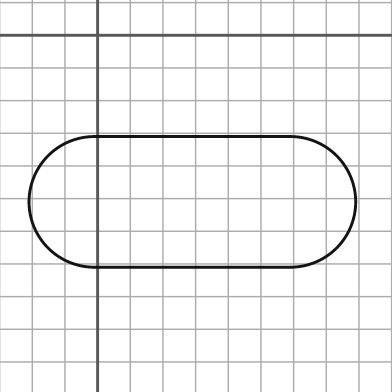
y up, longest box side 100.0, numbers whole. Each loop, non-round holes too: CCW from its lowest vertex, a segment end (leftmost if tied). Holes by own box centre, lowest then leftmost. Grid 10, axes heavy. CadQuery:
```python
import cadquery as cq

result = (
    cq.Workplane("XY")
    .moveTo(-1.0, -71.0)
    .lineTo(59.0, -71.0)
    .threePointArc((79.0, -51.0), (59.0, -31.0))
    .lineTo(-1.0, -31.0)
    .threePointArc((-21.0, -51.0), (-1.0, -71.0))
    .close()
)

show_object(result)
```